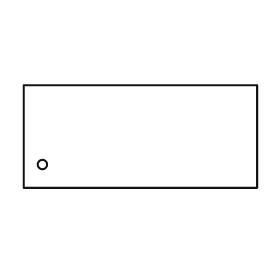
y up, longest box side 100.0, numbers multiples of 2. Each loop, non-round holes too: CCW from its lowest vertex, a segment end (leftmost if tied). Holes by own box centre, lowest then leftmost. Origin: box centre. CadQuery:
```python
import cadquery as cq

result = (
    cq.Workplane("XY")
    .moveTo(-50.0, -22.0)
    .lineTo(50.0, -22.0)
    .lineTo(50.0, 22.0)
    .lineTo(-50.0, 22.0)
    .close()
    .moveTo(-42.0, -12.0)
    .circle(2.0)
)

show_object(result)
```